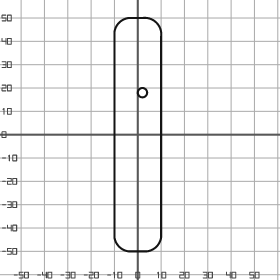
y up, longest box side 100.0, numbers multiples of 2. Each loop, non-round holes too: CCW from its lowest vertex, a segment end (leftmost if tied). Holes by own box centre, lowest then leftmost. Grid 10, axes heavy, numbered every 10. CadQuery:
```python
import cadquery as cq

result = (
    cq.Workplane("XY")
    .moveTo(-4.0, -50.0)
    .lineTo(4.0, -50.0)
    .threePointArc((8.0, -48.0), (10.0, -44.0))
    .lineTo(10.0, 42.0)
    .threePointArc((8.0, 48.0), (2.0, 50.0))
    .lineTo(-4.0, 50.0)
    .threePointArc((-8.0, 48.0), (-10.0, 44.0))
    .lineTo(-10.0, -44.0)
    .threePointArc((-8.0, -48.0), (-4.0, -50.0))
    .close()
    .moveTo(2.0, 18.0)
    .circle(2.0)
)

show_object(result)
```